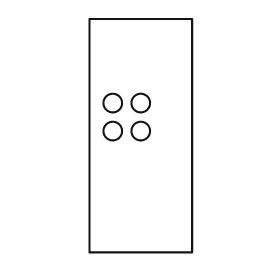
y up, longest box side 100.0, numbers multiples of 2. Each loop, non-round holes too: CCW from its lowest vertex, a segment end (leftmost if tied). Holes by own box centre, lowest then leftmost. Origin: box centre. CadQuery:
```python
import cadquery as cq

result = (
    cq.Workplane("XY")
    .moveTo(-22.0, -50.0)
    .lineTo(22.0, -50.0)
    .lineTo(22.0, 50.0)
    .lineTo(-22.0, 50.0)
    .close()
    .moveTo(-12.0, 2.0)
    .circle(4.0)
    .moveTo(0.0, 2.0)
    .circle(4.0)
    .moveTo(-12.0, 14.0)
    .circle(4.0)
    .moveTo(0.0, 14.0)
    .circle(4.0)
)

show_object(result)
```